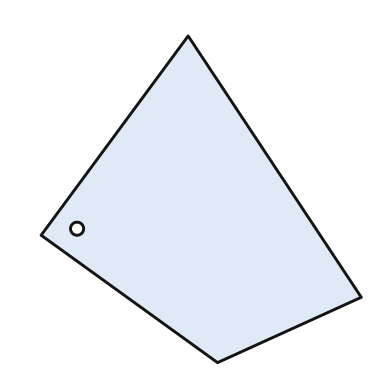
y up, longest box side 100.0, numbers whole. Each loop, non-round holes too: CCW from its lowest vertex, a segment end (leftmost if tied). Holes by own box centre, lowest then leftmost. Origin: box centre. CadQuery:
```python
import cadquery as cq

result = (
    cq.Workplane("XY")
    .moveTo(5.0, -50.0)
    .lineTo(49.0, -30.0)
    .lineTo(-4.0, 50.0)
    .lineTo(-49.0, -11.0)
    .close()
    .moveTo(-38.0, -9.0)
    .circle(2.0)
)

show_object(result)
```